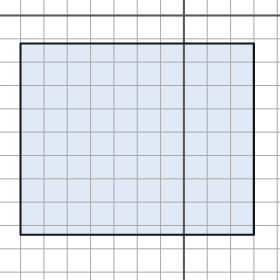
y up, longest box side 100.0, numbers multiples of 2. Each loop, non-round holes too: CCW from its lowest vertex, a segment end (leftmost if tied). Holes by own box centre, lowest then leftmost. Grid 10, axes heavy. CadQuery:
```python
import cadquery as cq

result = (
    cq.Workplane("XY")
    .moveTo(-70.0, -94.0)
    .lineTo(30.0, -94.0)
    .lineTo(30.0, -12.0)
    .lineTo(-70.0, -12.0)
    .close()
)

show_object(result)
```